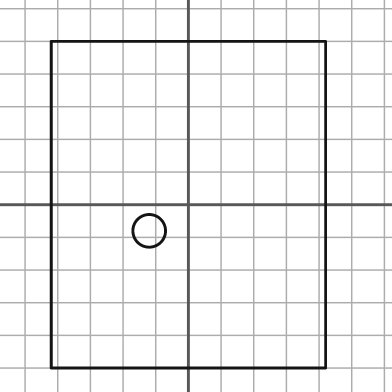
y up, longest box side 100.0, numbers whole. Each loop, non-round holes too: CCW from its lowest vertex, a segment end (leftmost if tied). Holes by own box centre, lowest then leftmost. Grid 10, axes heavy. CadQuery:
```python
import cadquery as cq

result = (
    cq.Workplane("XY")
    .moveTo(-42.0, -50.0)
    .lineTo(42.0, -50.0)
    .lineTo(42.0, 50.0)
    .lineTo(-42.0, 50.0)
    .close()
    .moveTo(-12.0, -8.0)
    .circle(5.0)
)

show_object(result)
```